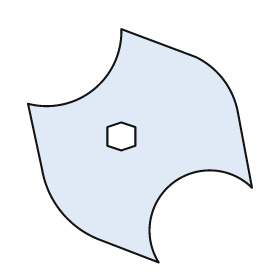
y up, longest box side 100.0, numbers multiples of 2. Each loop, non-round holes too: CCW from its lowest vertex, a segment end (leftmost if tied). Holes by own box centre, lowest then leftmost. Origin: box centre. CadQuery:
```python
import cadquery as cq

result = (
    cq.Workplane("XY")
    .moveTo(8.0, -50.0)
    .threePointArc((14.0, -16.0), (48.0, -18.0))
    .lineTo(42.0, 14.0)
    .threePointArc((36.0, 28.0), (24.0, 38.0))
    .lineTo(-8.0, 50.0)
    .threePointArc((-20.0, 24.0), (-48.0, 18.0))
    .lineTo(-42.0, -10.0)
    .threePointArc((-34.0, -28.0), (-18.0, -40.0))
    .close()
    .moveTo(-8.0, -2.0)
    .lineTo(-2.0, 0.0)
    .lineTo(-2.0, 8.0)
    .lineTo(-8.0, 10.0)
    .lineTo(-14.0, 8.0)
    .lineTo(-14.0, 0.0)
    .close()
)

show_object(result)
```